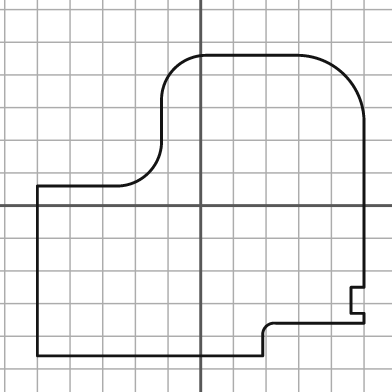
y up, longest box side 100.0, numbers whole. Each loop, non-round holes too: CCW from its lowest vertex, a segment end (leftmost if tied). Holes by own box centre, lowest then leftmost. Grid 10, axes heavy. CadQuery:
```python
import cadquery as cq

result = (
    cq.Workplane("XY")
    .moveTo(-50.0, -46.0)
    .lineTo(19.0, -46.0)
    .lineTo(19.0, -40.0)
    .threePointArc((20.0, -37.0), (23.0, -36.0))
    .lineTo(50.0, -36.0)
    .lineTo(50.0, -33.0)
    .lineTo(46.0, -33.0)
    .lineTo(46.0, -25.0)
    .lineTo(50.0, -25.0)
    .lineTo(50.0, 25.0)
    .threePointArc((44.0, 40.0), (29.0, 46.0))
    .lineTo(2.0, 46.0)
    .threePointArc((-8.0, 42.0), (-12.0, 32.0))
    .lineTo(-12.0, 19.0)
    .threePointArc((-16.0, 10.0), (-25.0, 6.0))
    .lineTo(-50.0, 6.0)
    .close()
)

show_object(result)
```